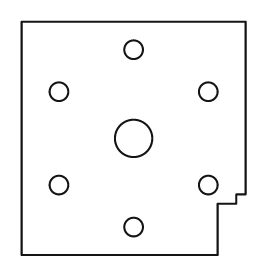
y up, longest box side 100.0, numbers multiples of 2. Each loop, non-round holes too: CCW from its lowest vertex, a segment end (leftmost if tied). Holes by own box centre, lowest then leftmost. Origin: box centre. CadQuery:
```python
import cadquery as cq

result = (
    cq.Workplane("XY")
    .moveTo(-48.0, -50.0)
    .lineTo(36.0, -50.0)
    .lineTo(36.0, -28.0)
    .lineTo(44.0, -28.0)
    .lineTo(44.0, -24.0)
    .lineTo(48.0, -24.0)
    .lineTo(48.0, 50.0)
    .lineTo(-48.0, 50.0)
    .close()
    .moveTo(0.0, -38.0)
    .circle(4.0)
    .moveTo(-32.0, -20.0)
    .circle(4.0)
    .moveTo(32.0, -20.0)
    .circle(4.0)
    .moveTo(0.0, 0.0)
    .circle(8.0)
    .moveTo(-32.0, 20.0)
    .circle(4.0)
    .moveTo(32.0, 20.0)
    .circle(4.0)
    .moveTo(0.0, 38.0)
    .circle(4.0)
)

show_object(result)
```